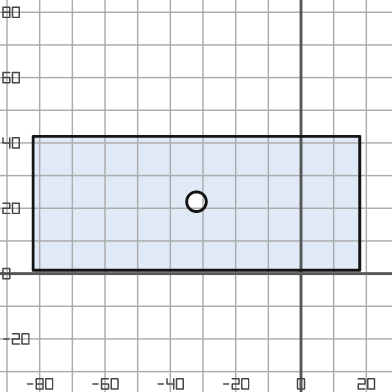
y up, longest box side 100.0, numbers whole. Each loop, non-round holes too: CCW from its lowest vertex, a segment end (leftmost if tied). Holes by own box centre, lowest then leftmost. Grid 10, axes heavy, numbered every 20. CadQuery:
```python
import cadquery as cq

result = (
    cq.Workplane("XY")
    .moveTo(-82.0, 1.0)
    .lineTo(18.0, 1.0)
    .lineTo(18.0, 42.0)
    .lineTo(-82.0, 42.0)
    .close()
    .moveTo(-32.0, 22.0)
    .circle(3.0)
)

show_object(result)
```